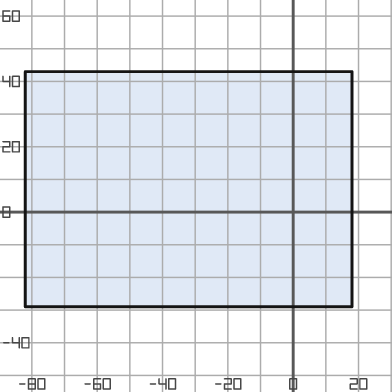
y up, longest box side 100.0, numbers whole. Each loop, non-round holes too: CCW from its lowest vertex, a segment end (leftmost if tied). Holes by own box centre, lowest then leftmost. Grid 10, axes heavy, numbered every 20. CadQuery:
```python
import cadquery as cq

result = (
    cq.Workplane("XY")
    .moveTo(-82.0, -29.0)
    .lineTo(18.0, -29.0)
    .lineTo(18.0, 43.0)
    .lineTo(-82.0, 43.0)
    .close()
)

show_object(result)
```